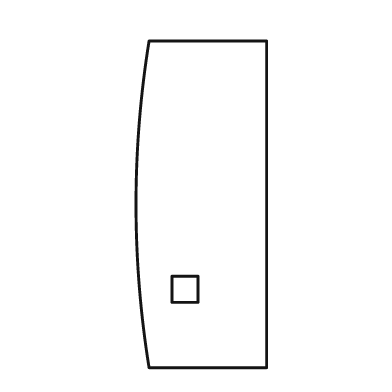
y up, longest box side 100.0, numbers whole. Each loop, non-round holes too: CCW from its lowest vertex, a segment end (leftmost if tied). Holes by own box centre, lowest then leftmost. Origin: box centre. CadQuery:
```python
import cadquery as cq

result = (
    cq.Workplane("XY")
    .moveTo(-16.0, -50.0)
    .lineTo(20.0, -50.0)
    .lineTo(20.0, 50.0)
    .lineTo(-16.0, 50.0)
    .threePointArc((-20.0, 0.0), (-16.0, -50.0))
    .close()
    .moveTo(-9.0, -30.0)
    .lineTo(-1.0, -30.0)
    .lineTo(-1.0, -22.0)
    .lineTo(-9.0, -22.0)
    .close()
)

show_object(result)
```